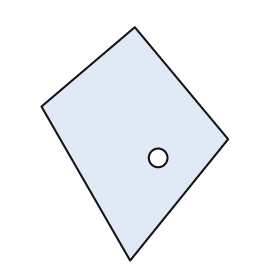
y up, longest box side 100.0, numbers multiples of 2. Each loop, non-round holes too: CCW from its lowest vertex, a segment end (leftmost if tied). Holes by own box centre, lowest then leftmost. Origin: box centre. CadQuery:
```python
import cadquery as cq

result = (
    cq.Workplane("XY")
    .moveTo(-2.0, -50.0)
    .lineTo(40.0, 2.0)
    .lineTo(0.0, 50.0)
    .lineTo(-40.0, 16.0)
    .close()
    .moveTo(10.0, -6.0)
    .circle(4.0)
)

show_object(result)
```